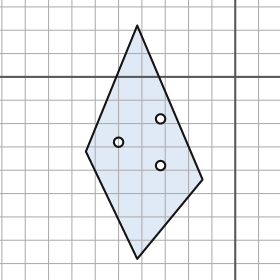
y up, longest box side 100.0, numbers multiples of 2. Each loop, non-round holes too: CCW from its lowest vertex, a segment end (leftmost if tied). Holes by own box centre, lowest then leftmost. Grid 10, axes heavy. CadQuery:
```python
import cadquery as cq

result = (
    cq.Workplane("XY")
    .moveTo(-42.0, -78.0)
    .lineTo(-14.0, -44.0)
    .lineTo(-42.0, 22.0)
    .lineTo(-64.0, -32.0)
    .close()
    .moveTo(-32.0, -38.0)
    .circle(2.0)
    .moveTo(-50.0, -28.0)
    .circle(2.0)
    .moveTo(-32.0, -18.0)
    .circle(2.0)
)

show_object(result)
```